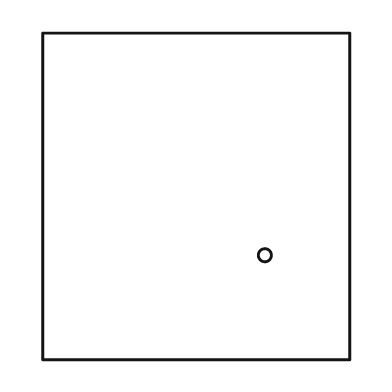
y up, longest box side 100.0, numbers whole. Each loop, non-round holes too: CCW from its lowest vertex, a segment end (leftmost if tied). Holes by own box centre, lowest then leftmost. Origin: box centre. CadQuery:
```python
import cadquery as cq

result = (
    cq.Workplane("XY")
    .moveTo(-47.0, -50.0)
    .lineTo(47.0, -50.0)
    .lineTo(47.0, 50.0)
    .lineTo(-47.0, 50.0)
    .close()
    .moveTo(21.0, -18.0)
    .circle(2.0)
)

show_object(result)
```